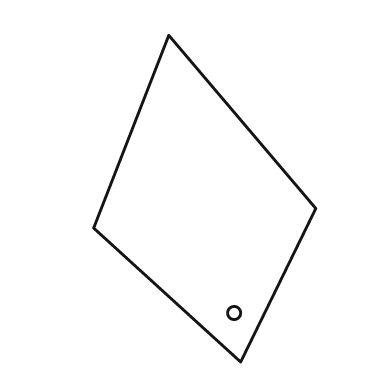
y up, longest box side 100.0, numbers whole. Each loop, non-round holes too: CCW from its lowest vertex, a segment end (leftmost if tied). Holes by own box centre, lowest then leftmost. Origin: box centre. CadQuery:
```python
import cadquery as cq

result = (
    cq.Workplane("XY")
    .moveTo(11.0, -50.0)
    .lineTo(34.0, -3.0)
    .lineTo(-11.0, 50.0)
    .lineTo(-34.0, -9.0)
    .close()
    .moveTo(9.0, -35.0)
    .circle(2.0)
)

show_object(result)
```